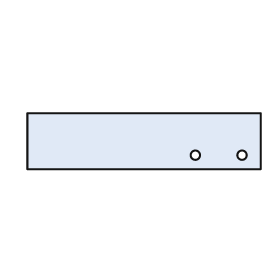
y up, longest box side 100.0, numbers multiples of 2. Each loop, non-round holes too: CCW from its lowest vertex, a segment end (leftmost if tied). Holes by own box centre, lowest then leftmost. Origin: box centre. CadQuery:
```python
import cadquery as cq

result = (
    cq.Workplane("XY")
    .moveTo(-50.0, -12.0)
    .lineTo(50.0, -12.0)
    .lineTo(50.0, 12.0)
    .lineTo(-50.0, 12.0)
    .close()
    .moveTo(22.0, -6.0)
    .circle(2.0)
    .moveTo(42.0, -6.0)
    .circle(2.0)
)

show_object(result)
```